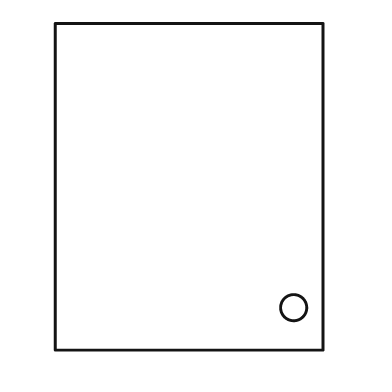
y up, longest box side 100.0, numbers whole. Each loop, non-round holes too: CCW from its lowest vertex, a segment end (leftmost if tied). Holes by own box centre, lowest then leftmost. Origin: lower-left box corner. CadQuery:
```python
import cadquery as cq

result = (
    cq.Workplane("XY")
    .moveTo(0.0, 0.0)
    .lineTo(82.0, 0.0)
    .lineTo(82.0, 100.0)
    .lineTo(0.0, 100.0)
    .close()
    .moveTo(73.0, 13.0)
    .circle(4.0)
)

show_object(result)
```